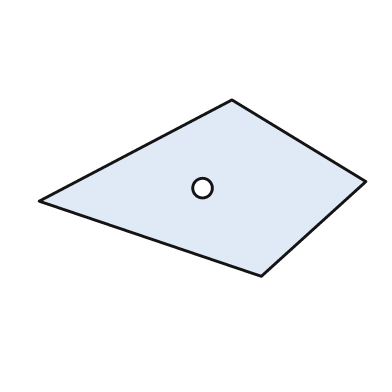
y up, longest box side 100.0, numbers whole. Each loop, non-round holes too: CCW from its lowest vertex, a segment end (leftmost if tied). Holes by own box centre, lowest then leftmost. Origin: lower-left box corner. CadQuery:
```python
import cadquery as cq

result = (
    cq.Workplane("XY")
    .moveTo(68.0, 0.0)
    .lineTo(100.0, 29.0)
    .lineTo(59.0, 54.0)
    .lineTo(0.0, 23.0)
    .close()
    .moveTo(50.0, 27.0)
    .circle(3.0)
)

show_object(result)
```